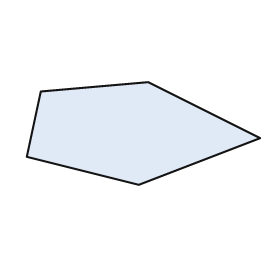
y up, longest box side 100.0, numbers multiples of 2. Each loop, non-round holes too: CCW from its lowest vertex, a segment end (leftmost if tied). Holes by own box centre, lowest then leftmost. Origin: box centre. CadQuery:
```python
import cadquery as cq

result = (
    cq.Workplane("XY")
    .moveTo(-2.0, -22.0)
    .lineTo(50.0, -2.0)
    .lineTo(2.0, 22.0)
    .lineTo(-44.0, 18.0)
    .lineTo(-50.0, -10.0)
    .close()
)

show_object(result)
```